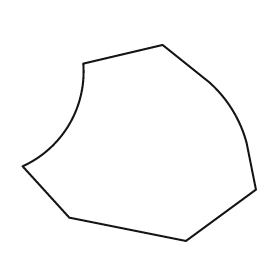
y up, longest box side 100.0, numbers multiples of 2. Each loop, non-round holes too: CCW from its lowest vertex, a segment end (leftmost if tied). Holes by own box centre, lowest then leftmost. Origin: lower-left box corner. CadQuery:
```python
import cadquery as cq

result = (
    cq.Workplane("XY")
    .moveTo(70.0, 0.0)
    .lineTo(100.0, 22.0)
    .lineTo(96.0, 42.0)
    .threePointArc((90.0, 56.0), (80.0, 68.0))
    .lineTo(60.0, 84.0)
    .lineTo(26.0, 76.0)
    .threePointArc((20.0, 50.0), (0.0, 32.0))
    .lineTo(20.0, 10.0)
    .close()
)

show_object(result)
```